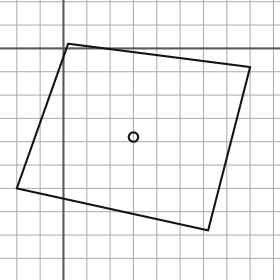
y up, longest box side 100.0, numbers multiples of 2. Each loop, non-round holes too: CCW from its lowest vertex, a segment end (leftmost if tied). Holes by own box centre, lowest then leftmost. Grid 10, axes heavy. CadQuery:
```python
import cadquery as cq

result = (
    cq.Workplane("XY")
    .moveTo(62.0, -78.0)
    .lineTo(80.0, -8.0)
    .lineTo(2.0, 2.0)
    .lineTo(-20.0, -60.0)
    .close()
    .moveTo(30.0, -38.0)
    .circle(2.0)
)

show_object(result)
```